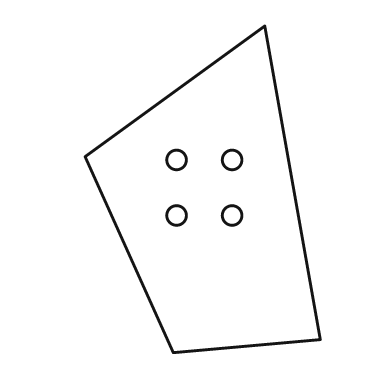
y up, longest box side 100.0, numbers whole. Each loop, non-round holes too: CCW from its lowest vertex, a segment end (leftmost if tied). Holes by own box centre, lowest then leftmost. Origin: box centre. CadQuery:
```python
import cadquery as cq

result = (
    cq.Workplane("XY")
    .moveTo(-9.0, -50.0)
    .lineTo(36.0, -46.0)
    .lineTo(19.0, 50.0)
    .lineTo(-36.0, 10.0)
    .close()
    .moveTo(-8.0, -8.0)
    .circle(3.0)
    .moveTo(9.0, -8.0)
    .circle(3.0)
    .moveTo(-8.0, 9.0)
    .circle(3.0)
    .moveTo(9.0, 9.0)
    .circle(3.0)
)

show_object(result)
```